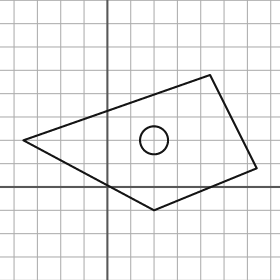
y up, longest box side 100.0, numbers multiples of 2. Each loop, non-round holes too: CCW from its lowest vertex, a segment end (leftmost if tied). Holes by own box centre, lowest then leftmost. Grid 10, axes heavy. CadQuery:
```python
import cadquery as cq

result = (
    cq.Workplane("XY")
    .moveTo(20.0, -10.0)
    .lineTo(64.0, 8.0)
    .lineTo(44.0, 48.0)
    .lineTo(-36.0, 20.0)
    .close()
    .moveTo(20.0, 20.0)
    .circle(6.0)
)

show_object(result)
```